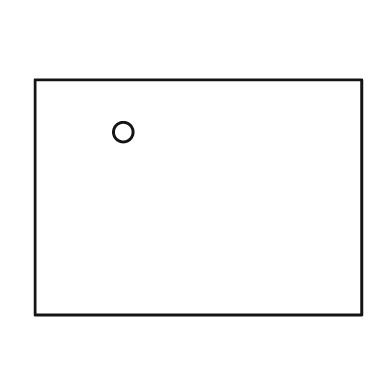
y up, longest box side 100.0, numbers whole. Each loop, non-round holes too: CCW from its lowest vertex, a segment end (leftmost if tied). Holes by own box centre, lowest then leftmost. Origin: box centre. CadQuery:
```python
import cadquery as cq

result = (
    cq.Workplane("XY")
    .moveTo(-50.0, -36.0)
    .lineTo(50.0, -36.0)
    .lineTo(50.0, 36.0)
    .lineTo(-50.0, 36.0)
    .close()
    .moveTo(-23.0, 20.0)
    .circle(3.0)
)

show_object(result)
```